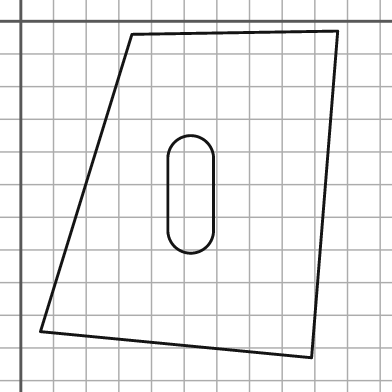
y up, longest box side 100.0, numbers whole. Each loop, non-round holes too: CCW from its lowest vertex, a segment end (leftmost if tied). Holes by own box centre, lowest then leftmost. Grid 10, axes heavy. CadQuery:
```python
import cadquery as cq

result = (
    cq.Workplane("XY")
    .moveTo(89.0, -103.0)
    .lineTo(97.0, -3.0)
    .lineTo(34.0, -4.0)
    .lineTo(6.0, -95.0)
    .close()
    .moveTo(45.0, -64.0)
    .threePointArc((52.0, -71.0), (59.0, -64.0))
    .lineTo(59.0, -42.0)
    .threePointArc((52.0, -35.0), (45.0, -42.0))
    .close()
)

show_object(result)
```